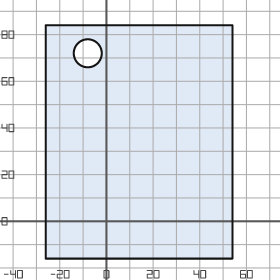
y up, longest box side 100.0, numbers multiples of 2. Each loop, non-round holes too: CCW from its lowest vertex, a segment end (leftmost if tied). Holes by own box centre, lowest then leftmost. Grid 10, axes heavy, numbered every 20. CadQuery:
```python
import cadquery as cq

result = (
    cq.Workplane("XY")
    .moveTo(-26.0, -16.0)
    .lineTo(54.0, -16.0)
    .lineTo(54.0, 84.0)
    .lineTo(-26.0, 84.0)
    .close()
    .moveTo(-8.0, 72.0)
    .circle(6.0)
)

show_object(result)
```